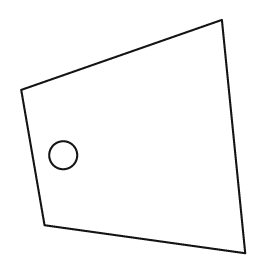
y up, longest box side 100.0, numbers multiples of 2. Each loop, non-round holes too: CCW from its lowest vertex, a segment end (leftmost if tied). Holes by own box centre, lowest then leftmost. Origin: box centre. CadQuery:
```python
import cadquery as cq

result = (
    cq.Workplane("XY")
    .moveTo(48.0, -50.0)
    .lineTo(38.0, 50.0)
    .lineTo(-48.0, 20.0)
    .lineTo(-38.0, -38.0)
    .close()
    .moveTo(-30.0, -8.0)
    .circle(6.0)
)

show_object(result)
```